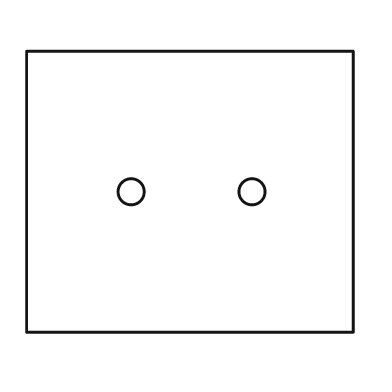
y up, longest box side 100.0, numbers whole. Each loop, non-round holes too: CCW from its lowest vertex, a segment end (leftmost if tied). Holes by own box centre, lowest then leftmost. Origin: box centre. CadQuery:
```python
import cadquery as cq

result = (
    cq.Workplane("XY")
    .moveTo(-50.0, -43.0)
    .lineTo(50.0, -43.0)
    .lineTo(50.0, 43.0)
    .lineTo(-50.0, 43.0)
    .close()
    .moveTo(-18.0, 0.0)
    .circle(4.0)
    .moveTo(19.0, 0.0)
    .circle(4.0)
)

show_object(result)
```